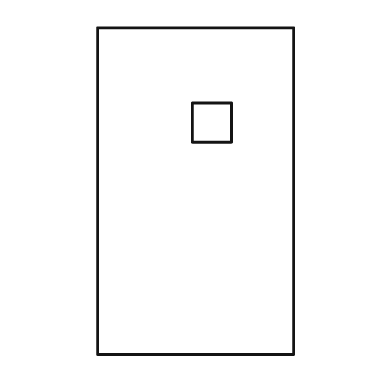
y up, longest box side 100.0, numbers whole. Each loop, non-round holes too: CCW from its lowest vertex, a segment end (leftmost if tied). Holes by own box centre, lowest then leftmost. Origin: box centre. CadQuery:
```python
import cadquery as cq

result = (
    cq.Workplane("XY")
    .moveTo(-30.0, -50.0)
    .lineTo(30.0, -50.0)
    .lineTo(30.0, 50.0)
    .lineTo(-30.0, 50.0)
    .close()
    .moveTo(-1.0, 15.0)
    .lineTo(11.0, 15.0)
    .lineTo(11.0, 27.0)
    .lineTo(-1.0, 27.0)
    .close()
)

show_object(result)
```